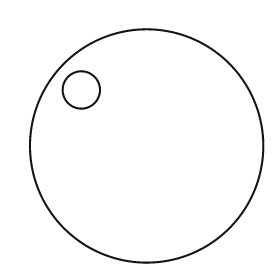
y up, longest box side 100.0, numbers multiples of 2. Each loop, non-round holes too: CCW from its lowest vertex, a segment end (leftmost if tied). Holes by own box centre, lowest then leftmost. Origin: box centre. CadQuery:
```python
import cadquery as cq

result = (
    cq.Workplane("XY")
    .moveTo(0.0, 0.0)
    .circle(50.0)
    .moveTo(-28.0, 24.0)
    .circle(8.0)
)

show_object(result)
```